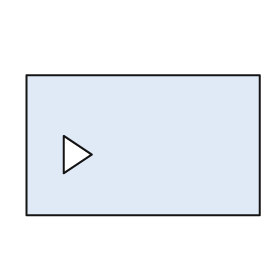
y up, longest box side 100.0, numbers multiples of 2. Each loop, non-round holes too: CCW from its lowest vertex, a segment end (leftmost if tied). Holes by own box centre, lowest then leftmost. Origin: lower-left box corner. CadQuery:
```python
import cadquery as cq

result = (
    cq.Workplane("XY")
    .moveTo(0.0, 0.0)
    .lineTo(100.0, 0.0)
    .lineTo(100.0, 60.0)
    .lineTo(0.0, 60.0)
    .close()
    .moveTo(16.0, 18.0)
    .lineTo(28.0, 26.0)
    .lineTo(16.0, 34.0)
    .close()
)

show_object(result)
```